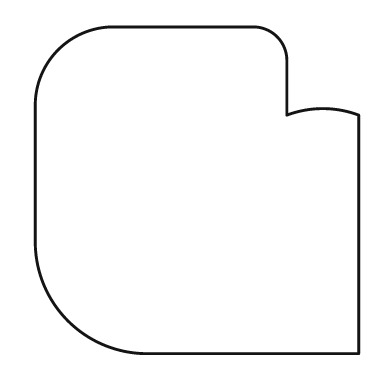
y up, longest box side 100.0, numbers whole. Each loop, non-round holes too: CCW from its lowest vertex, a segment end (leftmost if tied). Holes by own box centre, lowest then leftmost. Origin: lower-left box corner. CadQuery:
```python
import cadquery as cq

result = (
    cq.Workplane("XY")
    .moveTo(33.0, 0.0)
    .lineTo(99.0, 0.0)
    .lineTo(99.0, 73.0)
    .threePointArc((88.0, 75.0), (77.0, 73.0))
    .lineTo(77.0, 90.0)
    .threePointArc((74.0, 97.0), (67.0, 100.0))
    .lineTo(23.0, 100.0)
    .threePointArc((7.0, 93.0), (0.0, 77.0))
    .lineTo(0.0, 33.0)
    .threePointArc((10.0, 10.0), (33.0, 0.0))
    .close()
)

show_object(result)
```